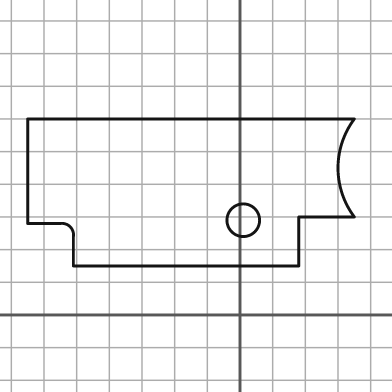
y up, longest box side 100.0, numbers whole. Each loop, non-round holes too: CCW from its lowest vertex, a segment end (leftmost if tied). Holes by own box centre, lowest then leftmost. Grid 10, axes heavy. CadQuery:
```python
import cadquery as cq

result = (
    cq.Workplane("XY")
    .moveTo(-51.0, 15.0)
    .lineTo(18.0, 15.0)
    .lineTo(18.0, 30.0)
    .lineTo(35.0, 30.0)
    .threePointArc((30.0, 45.0), (35.0, 60.0))
    .lineTo(-65.0, 60.0)
    .lineTo(-65.0, 28.0)
    .lineTo(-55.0, 28.0)
    .threePointArc((-52.0, 27.0), (-51.0, 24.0))
    .close()
    .moveTo(1.0, 29.0)
    .circle(5.0)
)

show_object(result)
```